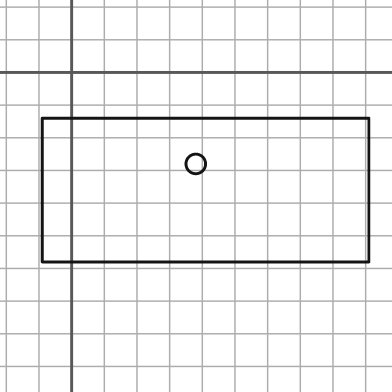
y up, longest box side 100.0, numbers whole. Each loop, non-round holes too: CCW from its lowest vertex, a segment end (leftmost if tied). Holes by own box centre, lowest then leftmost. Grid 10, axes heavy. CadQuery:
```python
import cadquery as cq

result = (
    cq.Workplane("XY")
    .moveTo(-9.0, -58.0)
    .lineTo(91.0, -58.0)
    .lineTo(91.0, -14.0)
    .lineTo(-9.0, -14.0)
    .close()
    .moveTo(38.0, -28.0)
    .circle(3.0)
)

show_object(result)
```